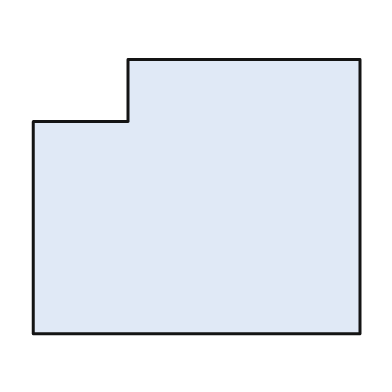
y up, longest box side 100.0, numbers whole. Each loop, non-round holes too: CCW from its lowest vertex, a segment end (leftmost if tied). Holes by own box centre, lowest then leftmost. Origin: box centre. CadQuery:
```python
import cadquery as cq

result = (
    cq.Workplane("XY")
    .moveTo(-50.0, -42.0)
    .lineTo(50.0, -42.0)
    .lineTo(50.0, 42.0)
    .lineTo(-21.0, 42.0)
    .lineTo(-21.0, 23.0)
    .lineTo(-50.0, 23.0)
    .close()
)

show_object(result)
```